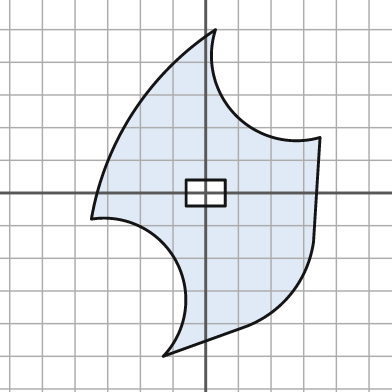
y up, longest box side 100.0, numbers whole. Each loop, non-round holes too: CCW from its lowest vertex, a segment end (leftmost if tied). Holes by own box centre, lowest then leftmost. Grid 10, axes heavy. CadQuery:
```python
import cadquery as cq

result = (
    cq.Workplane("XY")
    .moveTo(-13.0, -50.0)
    .lineTo(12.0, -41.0)
    .threePointArc((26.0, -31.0), (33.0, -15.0))
    .lineTo(35.0, 17.0)
    .threePointArc((9.0, 24.0), (3.0, 50.0))
    .threePointArc((-22.0, 25.0), (-35.0, -8.0))
    .threePointArc((-9.0, -21.0), (-13.0, -50.0))
    .close()
    .moveTo(-6.0, -4.0)
    .lineTo(6.0, -4.0)
    .lineTo(6.0, 4.0)
    .lineTo(-6.0, 4.0)
    .close()
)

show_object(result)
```